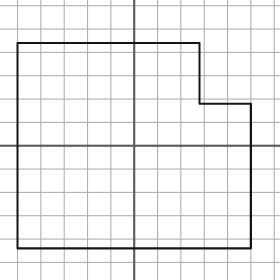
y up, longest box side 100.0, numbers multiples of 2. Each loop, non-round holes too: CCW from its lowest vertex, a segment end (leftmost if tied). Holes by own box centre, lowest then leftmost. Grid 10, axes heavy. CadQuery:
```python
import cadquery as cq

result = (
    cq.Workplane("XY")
    .moveTo(-50.0, -44.0)
    .lineTo(50.0, -44.0)
    .lineTo(50.0, 18.0)
    .lineTo(28.0, 18.0)
    .lineTo(28.0, 44.0)
    .lineTo(-50.0, 44.0)
    .close()
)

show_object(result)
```